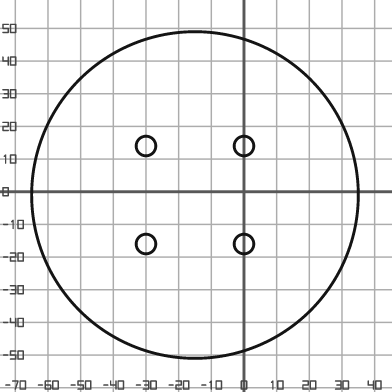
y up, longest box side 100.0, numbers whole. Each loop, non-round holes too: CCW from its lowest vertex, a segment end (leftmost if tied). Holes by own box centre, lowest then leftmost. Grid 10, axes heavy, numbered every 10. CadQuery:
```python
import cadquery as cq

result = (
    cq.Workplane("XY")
    .moveTo(-15.0, -1.0)
    .circle(50.0)
    .moveTo(-30.0, -16.0)
    .circle(3.0)
    .moveTo(0.0, -16.0)
    .circle(3.0)
    .moveTo(-30.0, 14.0)
    .circle(3.0)
    .moveTo(0.0, 14.0)
    .circle(3.0)
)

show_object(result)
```